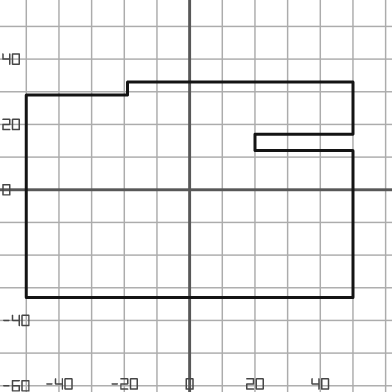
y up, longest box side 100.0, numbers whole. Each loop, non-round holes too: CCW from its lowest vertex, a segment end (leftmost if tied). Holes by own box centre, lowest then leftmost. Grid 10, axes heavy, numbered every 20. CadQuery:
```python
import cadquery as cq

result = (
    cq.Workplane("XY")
    .moveTo(-50.0, -33.0)
    .lineTo(50.0, -33.0)
    .lineTo(50.0, 12.0)
    .lineTo(20.0, 12.0)
    .lineTo(20.0, 17.0)
    .lineTo(50.0, 17.0)
    .lineTo(50.0, 33.0)
    .lineTo(-19.0, 33.0)
    .lineTo(-19.0, 29.0)
    .lineTo(-50.0, 29.0)
    .close()
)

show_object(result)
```